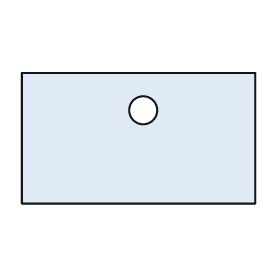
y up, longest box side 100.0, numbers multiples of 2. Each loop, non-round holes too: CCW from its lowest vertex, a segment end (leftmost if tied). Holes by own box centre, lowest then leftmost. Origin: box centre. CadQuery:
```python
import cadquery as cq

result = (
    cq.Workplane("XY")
    .moveTo(-50.0, -28.0)
    .lineTo(50.0, -28.0)
    .lineTo(50.0, 28.0)
    .lineTo(-50.0, 28.0)
    .close()
    .moveTo(2.0, 12.0)
    .circle(6.0)
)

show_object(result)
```